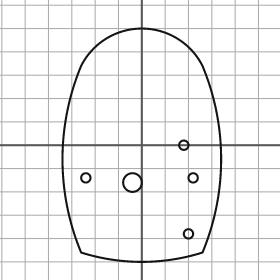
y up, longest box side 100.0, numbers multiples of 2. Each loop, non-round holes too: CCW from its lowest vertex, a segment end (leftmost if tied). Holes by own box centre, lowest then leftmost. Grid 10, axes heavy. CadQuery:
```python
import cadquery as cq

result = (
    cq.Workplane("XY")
    .moveTo(-26.0, -46.0)
    .threePointArc((0.0, -50.0), (26.0, -46.0))
    .threePointArc((34.0, -6.0), (26.0, 34.0))
    .threePointArc((0.0, 50.0), (-26.0, 34.0))
    .threePointArc((-34.0, -6.0), (-26.0, -46.0))
    .close()
    .moveTo(20.0, -38.0)
    .circle(2.0)
    .moveTo(-4.0, -16.0)
    .circle(4.0)
    .moveTo(-24.0, -14.0)
    .circle(2.0)
    .moveTo(22.0, -14.0)
    .circle(2.0)
    .moveTo(18.0, 0.0)
    .circle(2.0)
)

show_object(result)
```